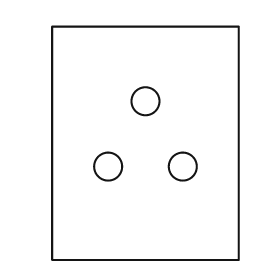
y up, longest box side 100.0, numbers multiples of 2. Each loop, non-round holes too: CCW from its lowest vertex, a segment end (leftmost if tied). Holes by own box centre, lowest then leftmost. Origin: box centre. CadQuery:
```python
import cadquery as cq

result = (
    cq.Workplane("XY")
    .moveTo(-40.0, -50.0)
    .lineTo(40.0, -50.0)
    .lineTo(40.0, 50.0)
    .lineTo(-40.0, 50.0)
    .close()
    .moveTo(-16.0, -10.0)
    .circle(6.0)
    .moveTo(16.0, -10.0)
    .circle(6.0)
    .moveTo(0.0, 18.0)
    .circle(6.0)
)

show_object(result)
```